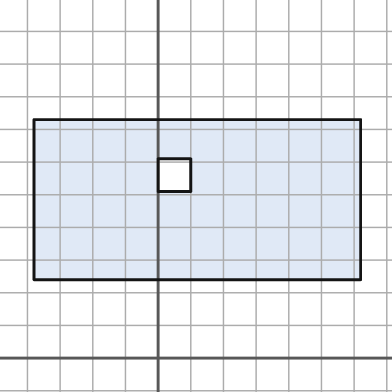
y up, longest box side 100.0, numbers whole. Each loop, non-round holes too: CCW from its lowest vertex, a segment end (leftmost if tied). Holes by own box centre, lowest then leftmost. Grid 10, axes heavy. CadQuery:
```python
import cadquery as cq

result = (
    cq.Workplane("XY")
    .moveTo(-38.0, 24.0)
    .lineTo(62.0, 24.0)
    .lineTo(62.0, 73.0)
    .lineTo(-38.0, 73.0)
    .close()
    .moveTo(0.0, 51.0)
    .lineTo(10.0, 51.0)
    .lineTo(10.0, 61.0)
    .lineTo(0.0, 61.0)
    .close()
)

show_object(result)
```